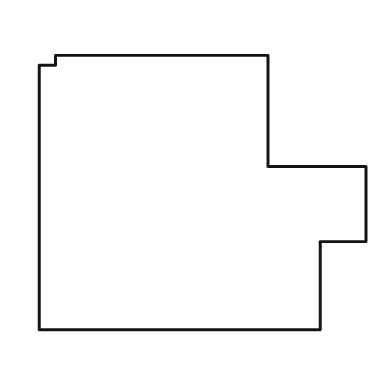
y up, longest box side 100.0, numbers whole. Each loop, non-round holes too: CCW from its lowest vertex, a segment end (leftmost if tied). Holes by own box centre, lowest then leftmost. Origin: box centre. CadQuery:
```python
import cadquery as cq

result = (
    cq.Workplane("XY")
    .moveTo(-50.0, -42.0)
    .lineTo(36.0, -42.0)
    .lineTo(36.0, -15.0)
    .lineTo(50.0, -15.0)
    .lineTo(50.0, 8.0)
    .lineTo(20.0, 8.0)
    .lineTo(20.0, 42.0)
    .lineTo(-45.0, 42.0)
    .lineTo(-45.0, 39.0)
    .lineTo(-50.0, 39.0)
    .close()
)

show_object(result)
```